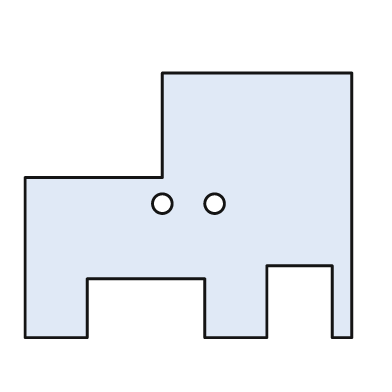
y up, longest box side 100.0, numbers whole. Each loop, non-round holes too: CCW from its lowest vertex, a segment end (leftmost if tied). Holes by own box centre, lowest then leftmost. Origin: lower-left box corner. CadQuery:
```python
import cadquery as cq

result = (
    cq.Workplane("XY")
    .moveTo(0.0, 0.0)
    .lineTo(19.0, 0.0)
    .lineTo(19.0, 18.0)
    .lineTo(55.0, 18.0)
    .lineTo(55.0, 0.0)
    .lineTo(74.0, 0.0)
    .lineTo(74.0, 22.0)
    .lineTo(94.0, 22.0)
    .lineTo(94.0, 0.0)
    .lineTo(100.0, 0.0)
    .lineTo(100.0, 81.0)
    .lineTo(42.0, 81.0)
    .lineTo(42.0, 49.0)
    .lineTo(0.0, 49.0)
    .close()
    .moveTo(42.0, 41.0)
    .circle(3.0)
    .moveTo(58.0, 41.0)
    .circle(3.0)
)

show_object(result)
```